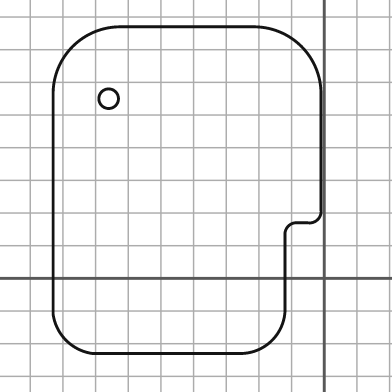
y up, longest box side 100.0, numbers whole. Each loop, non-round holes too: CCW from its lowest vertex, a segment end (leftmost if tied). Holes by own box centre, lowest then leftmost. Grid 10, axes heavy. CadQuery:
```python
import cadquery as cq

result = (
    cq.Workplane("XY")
    .moveTo(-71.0, -23.0)
    .lineTo(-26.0, -23.0)
    .threePointArc((-16.0, -19.0), (-12.0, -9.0))
    .lineTo(-12.0, 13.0)
    .threePointArc((-11.0, 16.0), (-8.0, 17.0))
    .lineTo(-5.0, 17.0)
    .threePointArc((-2.0, 18.0), (-1.0, 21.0))
    .lineTo(-1.0, 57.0)
    .threePointArc((-7.0, 71.0), (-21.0, 77.0))
    .lineTo(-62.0, 77.0)
    .threePointArc((-77.0, 71.0), (-83.0, 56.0))
    .lineTo(-83.0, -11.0)
    .threePointArc((-79.0, -19.0), (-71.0, -23.0))
    .close()
    .moveTo(-66.0, 55.0)
    .circle(3.0)
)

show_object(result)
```